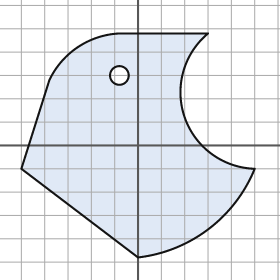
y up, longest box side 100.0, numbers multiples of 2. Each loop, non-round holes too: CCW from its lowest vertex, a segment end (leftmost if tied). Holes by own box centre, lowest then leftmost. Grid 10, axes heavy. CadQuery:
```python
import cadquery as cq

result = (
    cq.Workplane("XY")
    .moveTo(0.0, -48.0)
    .threePointArc((30.0, -36.0), (50.0, -10.0))
    .threePointArc((20.0, 12.0), (30.0, 48.0))
    .lineTo(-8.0, 48.0)
    .threePointArc((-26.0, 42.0), (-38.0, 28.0))
    .lineTo(-50.0, -10.0)
    .close()
    .moveTo(-8.0, 30.0)
    .circle(4.0)
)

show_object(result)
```